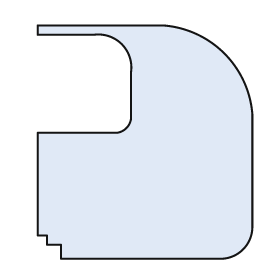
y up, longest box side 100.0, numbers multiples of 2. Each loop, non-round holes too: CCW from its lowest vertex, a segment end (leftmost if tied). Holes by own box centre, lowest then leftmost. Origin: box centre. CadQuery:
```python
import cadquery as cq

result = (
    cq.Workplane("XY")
    .moveTo(-36.0, -50.0)
    .lineTo(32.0, -50.0)
    .threePointArc((42.0, -46.0), (46.0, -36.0))
    .lineTo(46.0, 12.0)
    .threePointArc((34.0, 38.0), (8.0, 50.0))
    .lineTo(-46.0, 50.0)
    .lineTo(-46.0, 46.0)
    .lineTo(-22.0, 46.0)
    .threePointArc((-10.0, 42.0), (-6.0, 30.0))
    .lineTo(-6.0, 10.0)
    .threePointArc((-8.0, 6.0), (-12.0, 4.0))
    .lineTo(-46.0, 4.0)
    .lineTo(-46.0, -40.0)
    .lineTo(-42.0, -40.0)
    .lineTo(-42.0, -44.0)
    .lineTo(-36.0, -44.0)
    .close()
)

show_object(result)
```